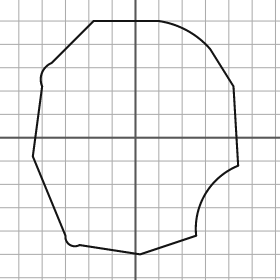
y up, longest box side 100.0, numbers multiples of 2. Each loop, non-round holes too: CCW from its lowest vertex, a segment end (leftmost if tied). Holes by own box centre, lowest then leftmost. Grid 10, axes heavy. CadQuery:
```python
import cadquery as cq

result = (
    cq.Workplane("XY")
    .moveTo(2.0, -50.0)
    .lineTo(26.0, -42.0)
    .threePointArc((30.0, -24.0), (44.0, -12.0))
    .lineTo(42.0, 22.0)
    .lineTo(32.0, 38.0)
    .threePointArc((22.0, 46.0), (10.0, 50.0))
    .lineTo(-18.0, 50.0)
    .lineTo(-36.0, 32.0)
    .threePointArc((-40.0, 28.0), (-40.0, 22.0))
    .lineTo(-44.0, -8.0)
    .lineTo(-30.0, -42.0)
    .threePointArc((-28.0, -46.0), (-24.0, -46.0))
    .close()
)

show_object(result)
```